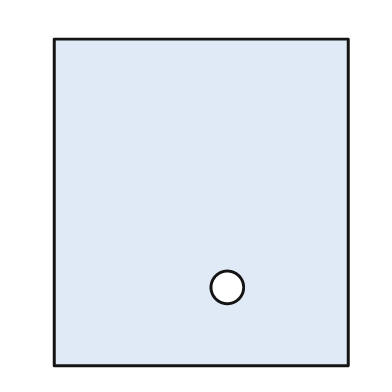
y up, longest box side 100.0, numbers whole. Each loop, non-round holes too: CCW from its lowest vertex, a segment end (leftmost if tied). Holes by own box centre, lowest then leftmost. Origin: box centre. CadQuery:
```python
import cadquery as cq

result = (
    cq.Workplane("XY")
    .moveTo(-45.0, -50.0)
    .lineTo(45.0, -50.0)
    .lineTo(45.0, 50.0)
    .lineTo(-45.0, 50.0)
    .close()
    .moveTo(8.0, -26.0)
    .circle(5.0)
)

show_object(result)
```